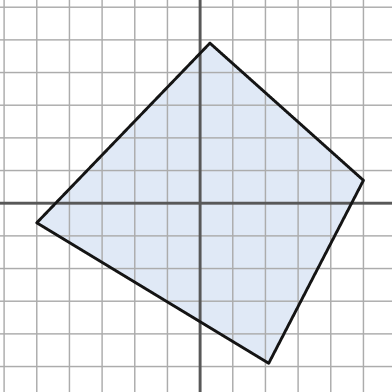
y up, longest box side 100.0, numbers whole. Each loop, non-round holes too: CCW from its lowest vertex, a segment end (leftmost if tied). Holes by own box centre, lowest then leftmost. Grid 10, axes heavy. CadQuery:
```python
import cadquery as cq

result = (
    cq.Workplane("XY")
    .moveTo(21.0, -49.0)
    .lineTo(50.0, 7.0)
    .lineTo(3.0, 49.0)
    .lineTo(-50.0, -6.0)
    .close()
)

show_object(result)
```